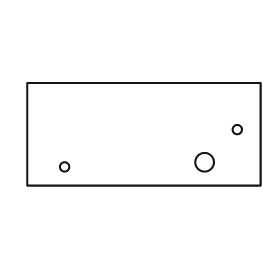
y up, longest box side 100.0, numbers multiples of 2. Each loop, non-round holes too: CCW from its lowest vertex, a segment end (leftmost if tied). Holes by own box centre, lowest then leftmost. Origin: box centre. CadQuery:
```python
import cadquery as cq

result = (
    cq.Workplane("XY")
    .moveTo(-50.0, -22.0)
    .lineTo(50.0, -22.0)
    .lineTo(50.0, 22.0)
    .lineTo(-50.0, 22.0)
    .close()
    .moveTo(-34.0, -14.0)
    .circle(2.0)
    .moveTo(26.0, -12.0)
    .circle(4.0)
    .moveTo(40.0, 2.0)
    .circle(2.0)
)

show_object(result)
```